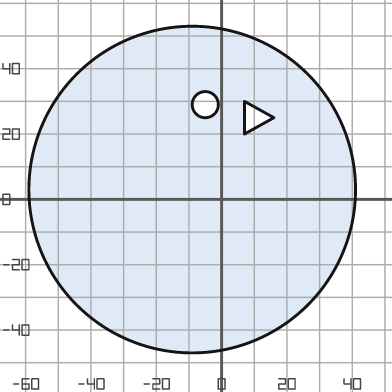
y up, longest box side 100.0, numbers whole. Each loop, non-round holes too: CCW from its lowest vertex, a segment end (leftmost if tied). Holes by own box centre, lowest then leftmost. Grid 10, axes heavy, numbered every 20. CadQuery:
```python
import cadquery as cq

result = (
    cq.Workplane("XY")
    .moveTo(-9.0, 3.0)
    .circle(50.0)
    .moveTo(7.0, 20.0)
    .lineTo(16.0, 25.0)
    .lineTo(7.0, 30.0)
    .close()
    .moveTo(-5.0, 29.0)
    .circle(4.0)
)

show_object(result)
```